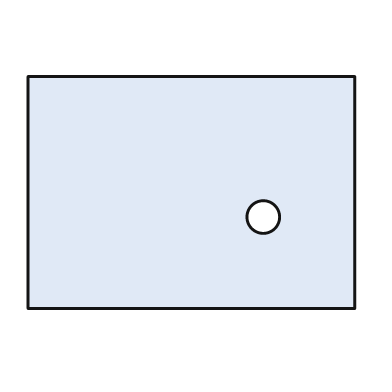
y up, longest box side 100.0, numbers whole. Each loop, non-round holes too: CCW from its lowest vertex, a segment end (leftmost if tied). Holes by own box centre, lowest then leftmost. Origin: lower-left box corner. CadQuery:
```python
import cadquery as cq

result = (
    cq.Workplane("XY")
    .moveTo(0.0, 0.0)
    .lineTo(100.0, 0.0)
    .lineTo(100.0, 71.0)
    .lineTo(0.0, 71.0)
    .close()
    .moveTo(72.0, 28.0)
    .circle(5.0)
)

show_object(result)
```